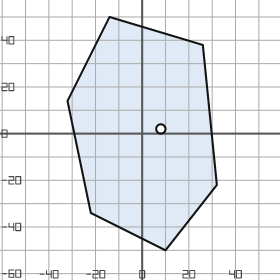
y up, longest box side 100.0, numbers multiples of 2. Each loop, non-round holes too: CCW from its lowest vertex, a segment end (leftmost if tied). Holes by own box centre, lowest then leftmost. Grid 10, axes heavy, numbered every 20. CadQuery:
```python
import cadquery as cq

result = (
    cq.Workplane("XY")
    .moveTo(10.0, -50.0)
    .lineTo(32.0, -22.0)
    .lineTo(26.0, 38.0)
    .lineTo(-14.0, 50.0)
    .lineTo(-32.0, 14.0)
    .lineTo(-22.0, -34.0)
    .close()
    .moveTo(8.0, 2.0)
    .circle(2.0)
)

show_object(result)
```